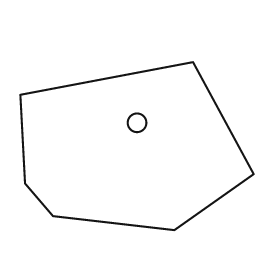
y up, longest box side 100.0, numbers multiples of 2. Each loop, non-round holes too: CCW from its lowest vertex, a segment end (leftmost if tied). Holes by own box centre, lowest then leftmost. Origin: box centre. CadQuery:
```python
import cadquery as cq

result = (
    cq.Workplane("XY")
    .moveTo(16.0, -36.0)
    .lineTo(50.0, -12.0)
    .lineTo(24.0, 36.0)
    .lineTo(-50.0, 22.0)
    .lineTo(-48.0, -16.0)
    .lineTo(-36.0, -30.0)
    .close()
    .moveTo(0.0, 10.0)
    .circle(4.0)
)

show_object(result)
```